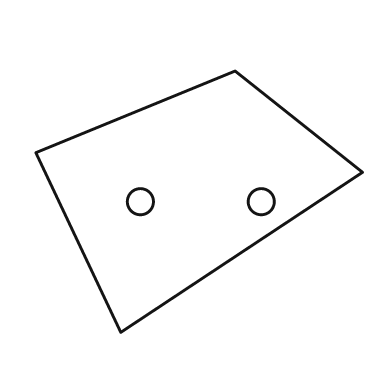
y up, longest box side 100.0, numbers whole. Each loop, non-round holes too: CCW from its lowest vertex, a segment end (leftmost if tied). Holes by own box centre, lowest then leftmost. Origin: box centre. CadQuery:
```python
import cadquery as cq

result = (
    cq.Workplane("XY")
    .moveTo(-24.0, -40.0)
    .lineTo(50.0, 9.0)
    .lineTo(11.0, 40.0)
    .lineTo(-50.0, 15.0)
    .close()
    .moveTo(-18.0, 0.0)
    .circle(4.0)
    .moveTo(19.0, 0.0)
    .circle(4.0)
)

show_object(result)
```